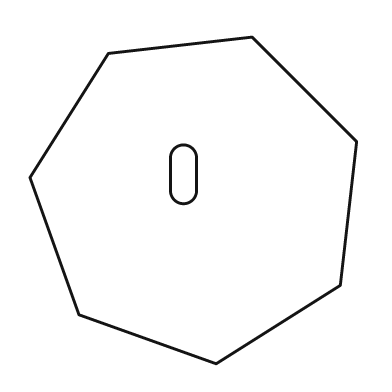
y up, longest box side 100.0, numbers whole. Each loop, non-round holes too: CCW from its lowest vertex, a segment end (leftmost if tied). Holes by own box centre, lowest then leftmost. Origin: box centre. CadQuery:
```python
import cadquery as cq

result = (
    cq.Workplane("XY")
    .moveTo(7.0, -50.0)
    .lineTo(45.0, -26.0)
    .lineTo(50.0, 18.0)
    .lineTo(18.0, 50.0)
    .lineTo(-26.0, 45.0)
    .lineTo(-50.0, 7.0)
    .lineTo(-35.0, -35.0)
    .close()
    .moveTo(-7.0, 3.0)
    .threePointArc((-3.0, -1.0), (1.0, 3.0))
    .lineTo(1.0, 13.0)
    .threePointArc((-3.0, 17.0), (-7.0, 13.0))
    .close()
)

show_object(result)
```